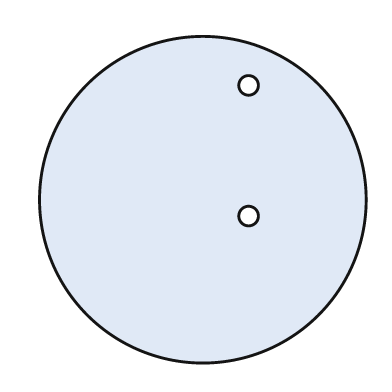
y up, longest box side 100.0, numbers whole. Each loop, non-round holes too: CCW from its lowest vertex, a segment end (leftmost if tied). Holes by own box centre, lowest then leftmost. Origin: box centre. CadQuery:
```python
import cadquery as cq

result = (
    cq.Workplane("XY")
    .moveTo(0.0, 0.0)
    .circle(50.0)
    .moveTo(14.0, -5.0)
    .circle(3.0)
    .moveTo(14.0, 35.0)
    .circle(3.0)
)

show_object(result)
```